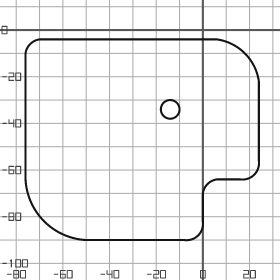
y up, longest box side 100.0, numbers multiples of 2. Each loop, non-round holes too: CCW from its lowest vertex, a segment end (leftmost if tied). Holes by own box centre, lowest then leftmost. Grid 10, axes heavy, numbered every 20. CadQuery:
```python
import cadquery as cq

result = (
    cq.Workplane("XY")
    .moveTo(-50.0, -90.0)
    .lineTo(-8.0, -90.0)
    .threePointArc((-2.0, -88.0), (0.0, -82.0))
    .lineTo(0.0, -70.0)
    .threePointArc((2.0, -66.0), (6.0, -64.0))
    .lineTo(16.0, -64.0)
    .threePointArc((22.0, -62.0), (24.0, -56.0))
    .lineTo(24.0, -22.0)
    .threePointArc((18.0, -10.0), (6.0, -4.0))
    .lineTo(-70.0, -4.0)
    .threePointArc((-74.0, -6.0), (-76.0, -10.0))
    .lineTo(-76.0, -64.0)
    .threePointArc((-68.0, -82.0), (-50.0, -90.0))
    .close()
    .moveTo(-14.0, -34.0)
    .circle(4.0)
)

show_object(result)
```